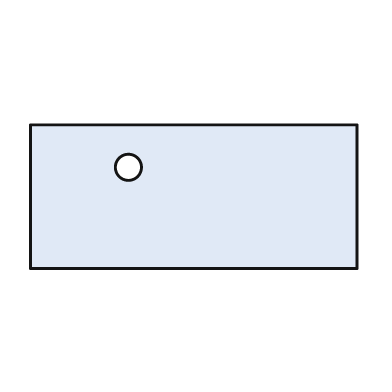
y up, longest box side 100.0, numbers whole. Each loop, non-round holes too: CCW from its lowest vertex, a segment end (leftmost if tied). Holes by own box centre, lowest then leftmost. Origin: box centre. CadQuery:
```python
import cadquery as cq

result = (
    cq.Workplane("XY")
    .moveTo(-50.0, -22.0)
    .lineTo(50.0, -22.0)
    .lineTo(50.0, 22.0)
    .lineTo(-50.0, 22.0)
    .close()
    .moveTo(-20.0, 9.0)
    .circle(4.0)
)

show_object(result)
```